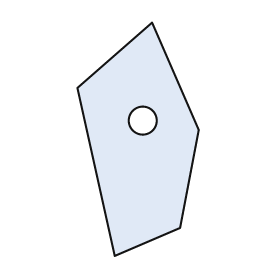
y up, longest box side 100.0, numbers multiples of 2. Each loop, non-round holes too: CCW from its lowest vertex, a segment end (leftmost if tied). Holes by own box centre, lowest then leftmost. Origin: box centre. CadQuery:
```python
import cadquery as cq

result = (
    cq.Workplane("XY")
    .moveTo(-10.0, -50.0)
    .lineTo(18.0, -38.0)
    .lineTo(26.0, 4.0)
    .lineTo(6.0, 50.0)
    .lineTo(-26.0, 22.0)
    .close()
    .moveTo(2.0, 8.0)
    .circle(6.0)
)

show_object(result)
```